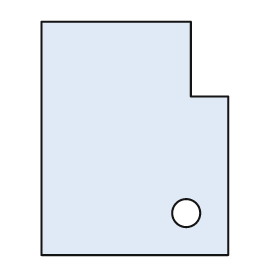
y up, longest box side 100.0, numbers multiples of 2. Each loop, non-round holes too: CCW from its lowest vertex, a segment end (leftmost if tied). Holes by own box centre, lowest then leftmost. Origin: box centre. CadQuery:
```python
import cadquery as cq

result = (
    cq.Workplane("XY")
    .moveTo(-40.0, -50.0)
    .lineTo(40.0, -50.0)
    .lineTo(40.0, 18.0)
    .lineTo(24.0, 18.0)
    .lineTo(24.0, 50.0)
    .lineTo(-40.0, 50.0)
    .close()
    .moveTo(22.0, -32.0)
    .circle(6.0)
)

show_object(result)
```